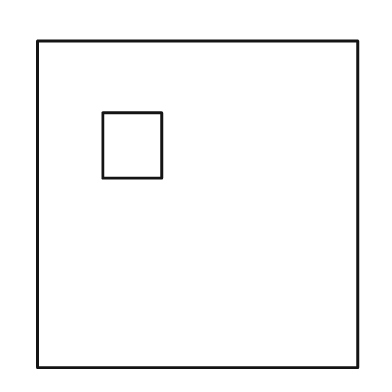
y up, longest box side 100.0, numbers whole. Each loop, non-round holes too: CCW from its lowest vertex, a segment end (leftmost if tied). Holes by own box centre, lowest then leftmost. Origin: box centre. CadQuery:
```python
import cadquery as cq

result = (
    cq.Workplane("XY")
    .moveTo(-49.0, -50.0)
    .lineTo(49.0, -50.0)
    .lineTo(49.0, 50.0)
    .lineTo(-49.0, 50.0)
    .close()
    .moveTo(-29.0, 8.0)
    .lineTo(-11.0, 8.0)
    .lineTo(-11.0, 28.0)
    .lineTo(-29.0, 28.0)
    .close()
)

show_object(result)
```